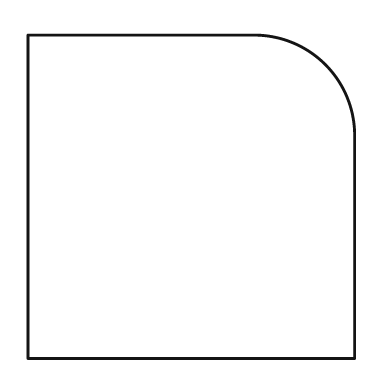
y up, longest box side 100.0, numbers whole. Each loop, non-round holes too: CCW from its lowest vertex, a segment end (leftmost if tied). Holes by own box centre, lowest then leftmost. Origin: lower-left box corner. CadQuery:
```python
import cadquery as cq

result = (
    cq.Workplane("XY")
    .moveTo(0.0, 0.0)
    .lineTo(100.0, 0.0)
    .lineTo(100.0, 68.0)
    .threePointArc((91.0, 90.0), (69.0, 99.0))
    .lineTo(0.0, 99.0)
    .close()
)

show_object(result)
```